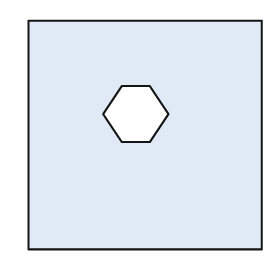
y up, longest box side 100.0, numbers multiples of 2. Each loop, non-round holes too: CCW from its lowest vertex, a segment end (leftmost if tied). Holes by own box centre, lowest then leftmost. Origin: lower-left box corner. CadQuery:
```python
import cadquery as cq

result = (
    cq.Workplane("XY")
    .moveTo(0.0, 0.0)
    .lineTo(100.0, 0.0)
    .lineTo(100.0, 98.0)
    .lineTo(0.0, 98.0)
    .close()
    .moveTo(40.0, 46.0)
    .lineTo(52.0, 46.0)
    .lineTo(60.0, 58.0)
    .lineTo(52.0, 70.0)
    .lineTo(40.0, 70.0)
    .lineTo(32.0, 58.0)
    .close()
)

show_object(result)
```